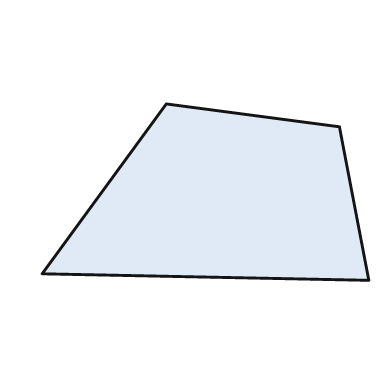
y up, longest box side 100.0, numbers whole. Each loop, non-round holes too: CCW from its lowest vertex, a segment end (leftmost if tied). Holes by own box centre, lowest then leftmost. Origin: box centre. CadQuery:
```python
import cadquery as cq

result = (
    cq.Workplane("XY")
    .moveTo(50.0, -27.0)
    .lineTo(41.0, 20.0)
    .lineTo(-12.0, 27.0)
    .lineTo(-50.0, -25.0)
    .close()
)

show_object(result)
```